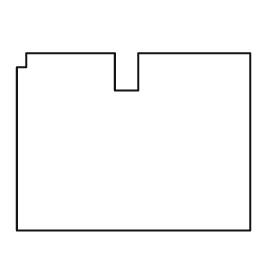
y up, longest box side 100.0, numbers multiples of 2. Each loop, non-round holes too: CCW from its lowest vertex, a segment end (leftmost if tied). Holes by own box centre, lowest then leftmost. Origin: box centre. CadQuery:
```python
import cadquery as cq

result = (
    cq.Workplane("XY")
    .moveTo(-50.0, -38.0)
    .lineTo(50.0, -38.0)
    .lineTo(50.0, 38.0)
    .lineTo(2.0, 38.0)
    .lineTo(2.0, 22.0)
    .lineTo(-8.0, 22.0)
    .lineTo(-8.0, 38.0)
    .lineTo(-46.0, 38.0)
    .lineTo(-46.0, 32.0)
    .lineTo(-50.0, 32.0)
    .close()
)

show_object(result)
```